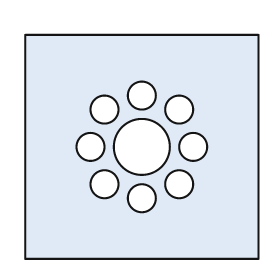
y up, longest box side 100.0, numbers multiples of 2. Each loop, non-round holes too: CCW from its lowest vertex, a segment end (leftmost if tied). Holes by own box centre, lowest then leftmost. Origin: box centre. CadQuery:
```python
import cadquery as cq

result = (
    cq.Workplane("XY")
    .moveTo(-50.0, -48.0)
    .lineTo(50.0, -48.0)
    .lineTo(50.0, 48.0)
    .lineTo(-50.0, 48.0)
    .close()
    .moveTo(0.0, -22.0)
    .circle(6.0)
    .moveTo(-16.0, -16.0)
    .circle(6.0)
    .moveTo(16.0, -16.0)
    .circle(6.0)
    .moveTo(-22.0, 0.0)
    .circle(6.0)
    .moveTo(0.0, 0.0)
    .circle(12.0)
    .moveTo(22.0, 0.0)
    .circle(6.0)
    .moveTo(-16.0, 16.0)
    .circle(6.0)
    .moveTo(16.0, 16.0)
    .circle(6.0)
    .moveTo(0.0, 22.0)
    .circle(6.0)
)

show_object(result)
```